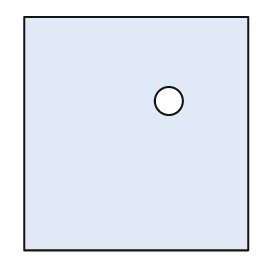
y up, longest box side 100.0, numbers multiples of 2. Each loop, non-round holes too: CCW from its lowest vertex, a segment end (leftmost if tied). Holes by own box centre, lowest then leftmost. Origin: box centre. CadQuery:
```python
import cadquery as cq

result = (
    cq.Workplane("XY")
    .moveTo(-48.0, -50.0)
    .lineTo(48.0, -50.0)
    .lineTo(48.0, 50.0)
    .lineTo(-48.0, 50.0)
    .close()
    .moveTo(14.0, 14.0)
    .circle(6.0)
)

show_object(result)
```